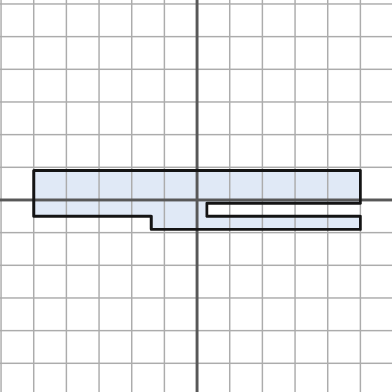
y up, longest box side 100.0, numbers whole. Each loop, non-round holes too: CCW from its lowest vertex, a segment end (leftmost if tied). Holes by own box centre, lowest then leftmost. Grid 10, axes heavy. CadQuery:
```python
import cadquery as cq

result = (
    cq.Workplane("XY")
    .moveTo(-14.0, -9.0)
    .lineTo(50.0, -9.0)
    .lineTo(50.0, -5.0)
    .lineTo(3.0, -5.0)
    .lineTo(3.0, -1.0)
    .lineTo(50.0, -1.0)
    .lineTo(50.0, 9.0)
    .lineTo(-50.0, 9.0)
    .lineTo(-50.0, -5.0)
    .lineTo(-14.0, -5.0)
    .close()
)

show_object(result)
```